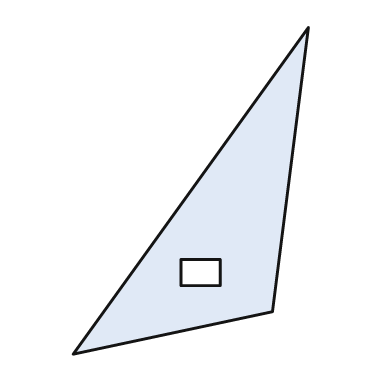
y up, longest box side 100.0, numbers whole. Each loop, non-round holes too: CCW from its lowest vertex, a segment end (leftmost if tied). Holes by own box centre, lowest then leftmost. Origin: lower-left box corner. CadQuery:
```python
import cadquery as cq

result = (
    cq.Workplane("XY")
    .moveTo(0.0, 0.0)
    .lineTo(61.0, 13.0)
    .lineTo(72.0, 100.0)
    .close()
    .moveTo(33.0, 21.0)
    .lineTo(45.0, 21.0)
    .lineTo(45.0, 29.0)
    .lineTo(33.0, 29.0)
    .close()
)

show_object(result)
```